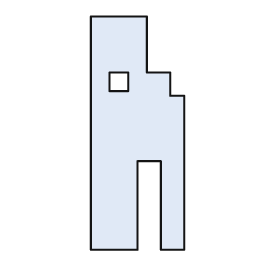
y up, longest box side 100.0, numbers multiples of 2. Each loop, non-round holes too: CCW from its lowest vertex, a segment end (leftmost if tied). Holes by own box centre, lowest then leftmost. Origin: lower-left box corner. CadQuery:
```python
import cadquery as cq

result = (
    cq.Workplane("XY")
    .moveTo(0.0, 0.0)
    .lineTo(20.0, 0.0)
    .lineTo(20.0, 38.0)
    .lineTo(30.0, 38.0)
    .lineTo(30.0, 0.0)
    .lineTo(40.0, 0.0)
    .lineTo(40.0, 66.0)
    .lineTo(34.0, 66.0)
    .lineTo(34.0, 76.0)
    .lineTo(24.0, 76.0)
    .lineTo(24.0, 100.0)
    .lineTo(0.0, 100.0)
    .close()
    .moveTo(8.0, 68.0)
    .lineTo(16.0, 68.0)
    .lineTo(16.0, 76.0)
    .lineTo(8.0, 76.0)
    .close()
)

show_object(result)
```